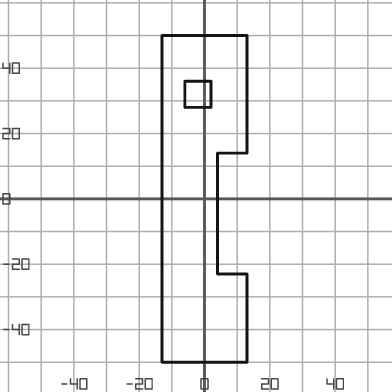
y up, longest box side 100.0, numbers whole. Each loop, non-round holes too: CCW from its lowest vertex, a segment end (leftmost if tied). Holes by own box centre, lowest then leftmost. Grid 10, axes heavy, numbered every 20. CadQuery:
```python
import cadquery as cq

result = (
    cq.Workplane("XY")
    .moveTo(-13.0, -50.0)
    .lineTo(13.0, -50.0)
    .lineTo(13.0, -23.0)
    .lineTo(4.0, -23.0)
    .lineTo(4.0, 14.0)
    .lineTo(13.0, 14.0)
    .lineTo(13.0, 50.0)
    .lineTo(-13.0, 50.0)
    .close()
    .moveTo(-6.0, 28.0)
    .lineTo(2.0, 28.0)
    .lineTo(2.0, 36.0)
    .lineTo(-6.0, 36.0)
    .close()
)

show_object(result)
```